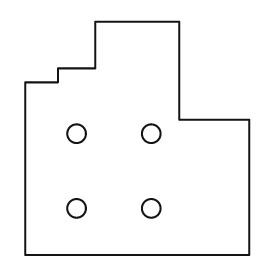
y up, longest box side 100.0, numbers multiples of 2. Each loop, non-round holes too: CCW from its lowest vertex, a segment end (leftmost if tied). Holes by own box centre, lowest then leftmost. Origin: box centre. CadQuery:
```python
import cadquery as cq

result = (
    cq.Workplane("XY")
    .moveTo(-48.0, -50.0)
    .lineTo(48.0, -50.0)
    .lineTo(48.0, 8.0)
    .lineTo(18.0, 8.0)
    .lineTo(18.0, 50.0)
    .lineTo(-18.0, 50.0)
    .lineTo(-18.0, 30.0)
    .lineTo(-34.0, 30.0)
    .lineTo(-34.0, 24.0)
    .lineTo(-48.0, 24.0)
    .close()
    .moveTo(-26.0, -30.0)
    .circle(4.0)
    .moveTo(6.0, -30.0)
    .circle(4.0)
    .moveTo(-26.0, 2.0)
    .circle(4.0)
    .moveTo(6.0, 2.0)
    .circle(4.0)
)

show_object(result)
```